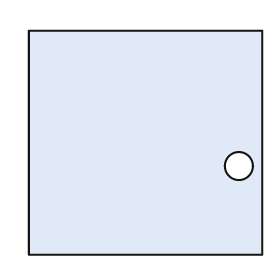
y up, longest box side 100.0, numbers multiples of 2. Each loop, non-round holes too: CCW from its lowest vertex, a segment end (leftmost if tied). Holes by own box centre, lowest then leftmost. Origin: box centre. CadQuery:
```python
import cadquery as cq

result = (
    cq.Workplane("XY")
    .moveTo(-50.0, -48.0)
    .lineTo(50.0, -48.0)
    .lineTo(50.0, 48.0)
    .lineTo(-50.0, 48.0)
    .close()
    .moveTo(40.0, -10.0)
    .circle(6.0)
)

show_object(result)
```